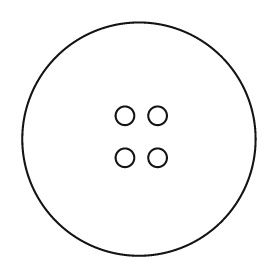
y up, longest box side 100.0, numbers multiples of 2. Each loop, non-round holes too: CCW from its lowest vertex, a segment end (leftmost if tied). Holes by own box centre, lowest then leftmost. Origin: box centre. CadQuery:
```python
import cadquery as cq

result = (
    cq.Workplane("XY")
    .moveTo(0.0, 0.0)
    .circle(50.0)
    .moveTo(-6.0, -8.0)
    .circle(4.0)
    .moveTo(8.0, -8.0)
    .circle(4.0)
    .moveTo(-6.0, 10.0)
    .circle(4.0)
    .moveTo(8.0, 10.0)
    .circle(4.0)
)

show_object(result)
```